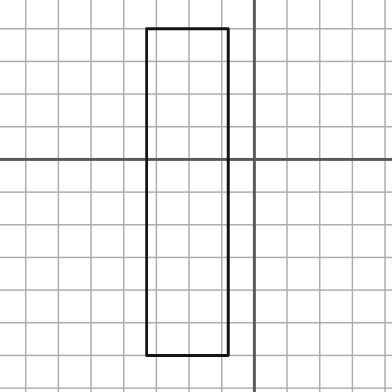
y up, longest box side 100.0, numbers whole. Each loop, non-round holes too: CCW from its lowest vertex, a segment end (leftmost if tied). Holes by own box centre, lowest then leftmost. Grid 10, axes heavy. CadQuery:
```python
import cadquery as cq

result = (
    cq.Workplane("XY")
    .moveTo(-33.0, -60.0)
    .lineTo(-8.0, -60.0)
    .lineTo(-8.0, 40.0)
    .lineTo(-33.0, 40.0)
    .close()
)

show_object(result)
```